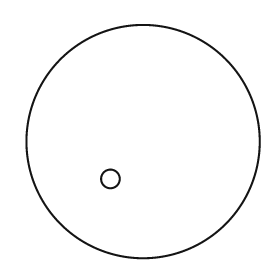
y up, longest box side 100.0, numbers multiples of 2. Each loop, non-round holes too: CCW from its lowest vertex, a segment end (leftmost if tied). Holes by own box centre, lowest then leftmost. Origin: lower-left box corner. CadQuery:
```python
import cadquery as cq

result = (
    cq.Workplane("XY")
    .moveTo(50.0, 50.0)
    .circle(50.0)
    .moveTo(36.0, 34.0)
    .circle(4.0)
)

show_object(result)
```